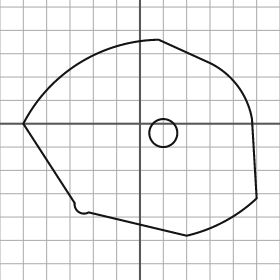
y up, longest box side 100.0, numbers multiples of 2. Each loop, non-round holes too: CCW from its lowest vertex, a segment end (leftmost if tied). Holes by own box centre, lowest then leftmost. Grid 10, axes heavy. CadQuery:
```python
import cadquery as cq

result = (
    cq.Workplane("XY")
    .moveTo(20.0, -48.0)
    .threePointArc((36.0, -42.0), (50.0, -32.0))
    .lineTo(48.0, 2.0)
    .threePointArc((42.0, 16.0), (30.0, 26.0))
    .lineTo(8.0, 36.0)
    .threePointArc((-26.0, 26.0), (-50.0, 0.0))
    .lineTo(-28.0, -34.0)
    .threePointArc((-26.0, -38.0), (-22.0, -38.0))
    .close()
    .moveTo(10.0, -4.0)
    .circle(6.0)
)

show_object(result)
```